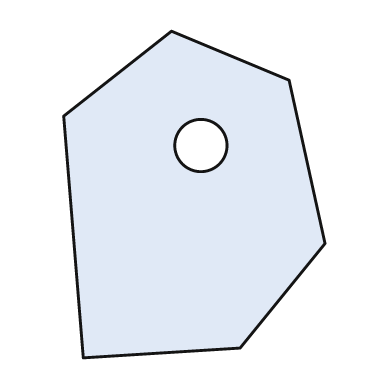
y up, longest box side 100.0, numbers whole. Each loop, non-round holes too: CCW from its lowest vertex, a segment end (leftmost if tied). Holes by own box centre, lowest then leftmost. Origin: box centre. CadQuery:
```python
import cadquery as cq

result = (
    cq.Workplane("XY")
    .moveTo(-34.0, -50.0)
    .lineTo(14.0, -47.0)
    .lineTo(40.0, -15.0)
    .lineTo(29.0, 35.0)
    .lineTo(-7.0, 50.0)
    .lineTo(-40.0, 24.0)
    .close()
    .moveTo(2.0, 15.0)
    .circle(8.0)
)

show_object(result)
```